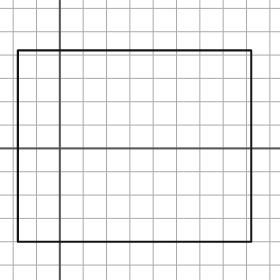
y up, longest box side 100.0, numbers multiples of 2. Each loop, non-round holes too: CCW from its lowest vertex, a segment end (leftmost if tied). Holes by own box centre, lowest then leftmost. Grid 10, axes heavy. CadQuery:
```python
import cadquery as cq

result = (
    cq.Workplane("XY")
    .moveTo(-18.0, -40.0)
    .lineTo(82.0, -40.0)
    .lineTo(82.0, 42.0)
    .lineTo(-18.0, 42.0)
    .close()
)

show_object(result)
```